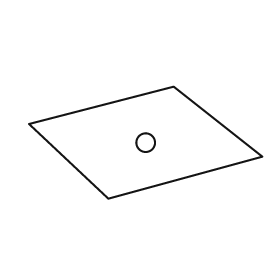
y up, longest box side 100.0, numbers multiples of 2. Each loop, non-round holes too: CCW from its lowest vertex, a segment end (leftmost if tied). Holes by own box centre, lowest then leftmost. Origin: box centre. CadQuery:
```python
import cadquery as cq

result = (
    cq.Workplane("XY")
    .moveTo(-16.0, -24.0)
    .lineTo(50.0, -6.0)
    .lineTo(12.0, 24.0)
    .lineTo(-50.0, 8.0)
    .close()
    .moveTo(0.0, 0.0)
    .circle(4.0)
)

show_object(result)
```